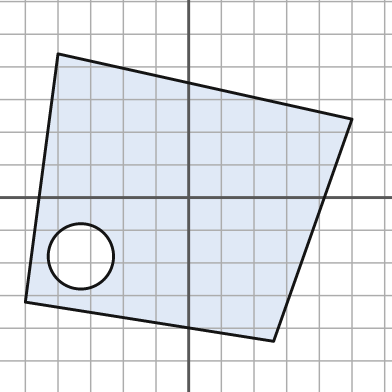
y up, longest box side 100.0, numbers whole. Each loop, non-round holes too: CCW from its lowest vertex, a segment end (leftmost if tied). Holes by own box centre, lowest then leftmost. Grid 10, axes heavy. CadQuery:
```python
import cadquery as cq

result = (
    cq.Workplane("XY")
    .moveTo(26.0, -44.0)
    .lineTo(50.0, 24.0)
    .lineTo(-40.0, 44.0)
    .lineTo(-50.0, -32.0)
    .close()
    .moveTo(-33.0, -18.0)
    .circle(10.0)
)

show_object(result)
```